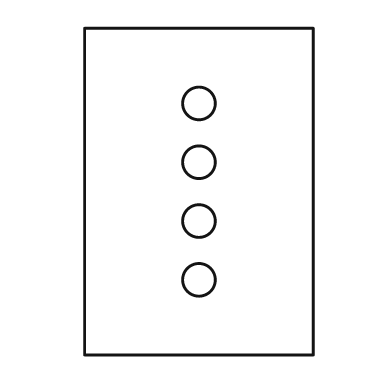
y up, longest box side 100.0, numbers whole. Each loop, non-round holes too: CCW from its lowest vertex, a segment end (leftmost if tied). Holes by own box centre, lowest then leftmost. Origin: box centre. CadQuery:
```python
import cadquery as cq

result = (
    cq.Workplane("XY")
    .moveTo(-35.0, -50.0)
    .lineTo(35.0, -50.0)
    .lineTo(35.0, 50.0)
    .lineTo(-35.0, 50.0)
    .close()
    .moveTo(0.0, -27.0)
    .circle(5.0)
    .moveTo(0.0, -9.0)
    .circle(5.0)
    .moveTo(0.0, 9.0)
    .circle(5.0)
    .moveTo(0.0, 27.0)
    .circle(5.0)
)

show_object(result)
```